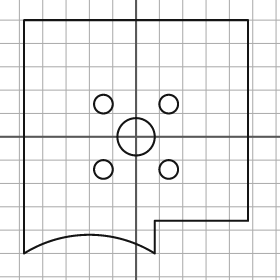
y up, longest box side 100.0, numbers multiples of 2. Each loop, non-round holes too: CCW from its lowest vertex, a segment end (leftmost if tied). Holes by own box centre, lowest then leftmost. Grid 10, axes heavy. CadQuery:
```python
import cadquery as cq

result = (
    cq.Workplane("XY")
    .moveTo(-48.0, -50.0)
    .threePointArc((-20.0, -42.0), (8.0, -50.0))
    .lineTo(8.0, -36.0)
    .lineTo(48.0, -36.0)
    .lineTo(48.0, 50.0)
    .lineTo(-48.0, 50.0)
    .close()
    .moveTo(-14.0, -14.0)
    .circle(4.0)
    .moveTo(14.0, -14.0)
    .circle(4.0)
    .moveTo(0.0, 0.0)
    .circle(8.0)
    .moveTo(-14.0, 14.0)
    .circle(4.0)
    .moveTo(14.0, 14.0)
    .circle(4.0)
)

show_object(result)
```